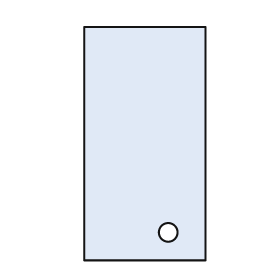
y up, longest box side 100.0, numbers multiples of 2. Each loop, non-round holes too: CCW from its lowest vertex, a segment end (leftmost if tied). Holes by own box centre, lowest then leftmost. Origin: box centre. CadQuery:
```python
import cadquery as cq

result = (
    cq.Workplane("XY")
    .moveTo(-26.0, -50.0)
    .lineTo(26.0, -50.0)
    .lineTo(26.0, 50.0)
    .lineTo(-26.0, 50.0)
    .close()
    .moveTo(10.0, -38.0)
    .circle(4.0)
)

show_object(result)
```